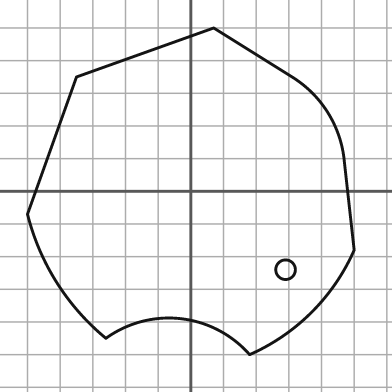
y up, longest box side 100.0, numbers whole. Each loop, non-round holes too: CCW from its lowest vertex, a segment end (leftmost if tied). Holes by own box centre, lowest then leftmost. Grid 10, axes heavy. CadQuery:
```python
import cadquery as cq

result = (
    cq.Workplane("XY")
    .moveTo(18.0, -50.0)
    .threePointArc((37.0, -37.0), (50.0, -18.0))
    .lineTo(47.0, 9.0)
    .threePointArc((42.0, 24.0), (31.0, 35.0))
    .lineTo(7.0, 50.0)
    .lineTo(-35.0, 35.0)
    .lineTo(-50.0, -7.0)
    .threePointArc((-41.0, -28.0), (-26.0, -45.0))
    .threePointArc((-3.0, -39.0), (18.0, -50.0))
    .close()
    .moveTo(29.0, -24.0)
    .circle(3.0)
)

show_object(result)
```